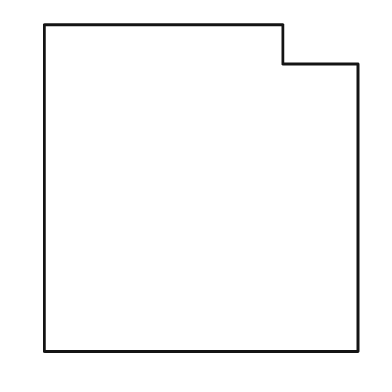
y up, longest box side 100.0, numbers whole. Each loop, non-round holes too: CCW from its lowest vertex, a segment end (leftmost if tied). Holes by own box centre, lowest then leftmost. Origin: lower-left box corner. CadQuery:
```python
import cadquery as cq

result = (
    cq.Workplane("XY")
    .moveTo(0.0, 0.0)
    .lineTo(96.0, 0.0)
    .lineTo(96.0, 88.0)
    .lineTo(73.0, 88.0)
    .lineTo(73.0, 100.0)
    .lineTo(0.0, 100.0)
    .close()
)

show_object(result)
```